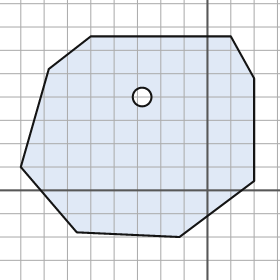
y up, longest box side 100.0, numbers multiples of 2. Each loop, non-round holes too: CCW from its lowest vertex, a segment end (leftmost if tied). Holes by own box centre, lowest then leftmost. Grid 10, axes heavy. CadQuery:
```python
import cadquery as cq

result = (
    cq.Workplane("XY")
    .moveTo(-12.0, -20.0)
    .lineTo(20.0, 4.0)
    .lineTo(20.0, 48.0)
    .lineTo(10.0, 66.0)
    .lineTo(-50.0, 66.0)
    .lineTo(-68.0, 52.0)
    .lineTo(-80.0, 10.0)
    .lineTo(-56.0, -18.0)
    .close()
    .moveTo(-28.0, 40.0)
    .circle(4.0)
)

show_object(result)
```